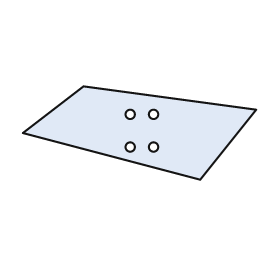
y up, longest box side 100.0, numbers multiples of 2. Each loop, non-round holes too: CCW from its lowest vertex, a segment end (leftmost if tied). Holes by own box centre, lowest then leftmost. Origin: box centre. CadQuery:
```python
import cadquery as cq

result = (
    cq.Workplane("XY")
    .moveTo(26.0, -20.0)
    .lineTo(50.0, 10.0)
    .lineTo(-24.0, 20.0)
    .lineTo(-50.0, 0.0)
    .close()
    .moveTo(-4.0, -6.0)
    .circle(2.0)
    .moveTo(6.0, -6.0)
    .circle(2.0)
    .moveTo(-4.0, 8.0)
    .circle(2.0)
    .moveTo(6.0, 8.0)
    .circle(2.0)
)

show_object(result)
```